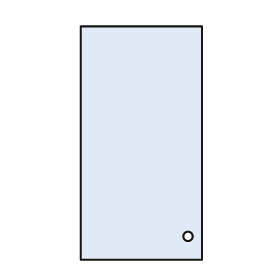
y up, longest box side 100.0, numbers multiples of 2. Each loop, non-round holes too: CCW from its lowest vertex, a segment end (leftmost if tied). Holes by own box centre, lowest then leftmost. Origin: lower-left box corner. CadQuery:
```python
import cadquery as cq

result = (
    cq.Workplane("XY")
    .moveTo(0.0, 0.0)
    .lineTo(52.0, 0.0)
    .lineTo(52.0, 100.0)
    .lineTo(0.0, 100.0)
    .close()
    .moveTo(46.0, 10.0)
    .circle(2.0)
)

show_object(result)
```